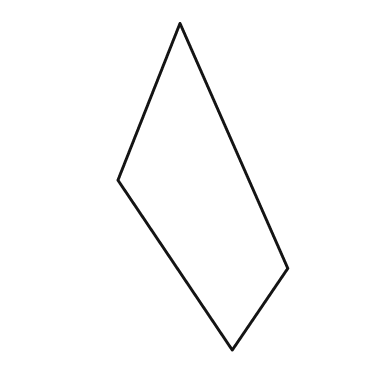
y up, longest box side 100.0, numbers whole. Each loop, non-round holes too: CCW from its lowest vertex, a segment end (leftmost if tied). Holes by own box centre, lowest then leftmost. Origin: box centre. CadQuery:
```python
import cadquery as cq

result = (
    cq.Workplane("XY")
    .moveTo(9.0, -50.0)
    .lineTo(26.0, -25.0)
    .lineTo(-7.0, 50.0)
    .lineTo(-26.0, 2.0)
    .close()
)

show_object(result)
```